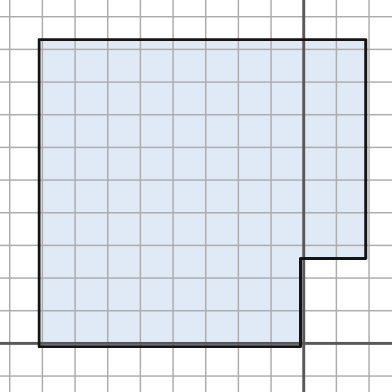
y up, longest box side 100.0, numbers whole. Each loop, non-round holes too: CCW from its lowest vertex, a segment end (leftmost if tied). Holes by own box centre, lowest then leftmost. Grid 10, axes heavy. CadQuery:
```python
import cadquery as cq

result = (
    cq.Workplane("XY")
    .moveTo(-81.0, -1.0)
    .lineTo(-1.0, -1.0)
    .lineTo(-1.0, 26.0)
    .lineTo(19.0, 26.0)
    .lineTo(19.0, 93.0)
    .lineTo(-81.0, 93.0)
    .close()
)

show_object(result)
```